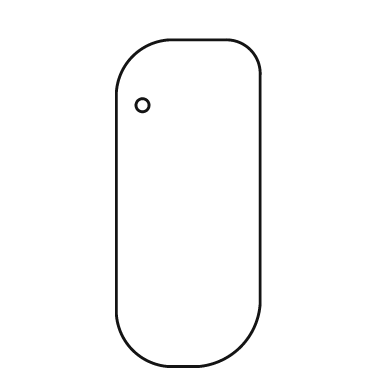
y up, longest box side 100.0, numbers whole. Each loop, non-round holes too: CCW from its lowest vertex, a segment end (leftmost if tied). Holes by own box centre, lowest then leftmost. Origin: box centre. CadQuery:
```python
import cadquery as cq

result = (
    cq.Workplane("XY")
    .moveTo(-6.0, -50.0)
    .lineTo(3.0, -50.0)
    .threePointArc((16.0, -44.0), (22.0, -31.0))
    .lineTo(22.0, 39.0)
    .threePointArc((19.0, 47.0), (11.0, 50.0))
    .lineTo(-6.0, 50.0)
    .threePointArc((-17.0, 45.0), (-22.0, 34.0))
    .lineTo(-22.0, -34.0)
    .threePointArc((-17.0, -45.0), (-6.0, -50.0))
    .close()
    .moveTo(-14.0, 30.0)
    .circle(2.0)
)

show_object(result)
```